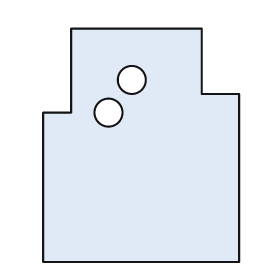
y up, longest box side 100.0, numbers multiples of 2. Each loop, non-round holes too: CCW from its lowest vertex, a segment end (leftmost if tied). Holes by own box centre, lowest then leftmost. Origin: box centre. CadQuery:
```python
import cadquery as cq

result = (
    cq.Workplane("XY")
    .moveTo(-42.0, -50.0)
    .lineTo(42.0, -50.0)
    .lineTo(42.0, 22.0)
    .lineTo(26.0, 22.0)
    .lineTo(26.0, 50.0)
    .lineTo(-30.0, 50.0)
    .lineTo(-30.0, 14.0)
    .lineTo(-42.0, 14.0)
    .close()
    .moveTo(-14.0, 14.0)
    .circle(6.0)
    .moveTo(-4.0, 28.0)
    .circle(6.0)
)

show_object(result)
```